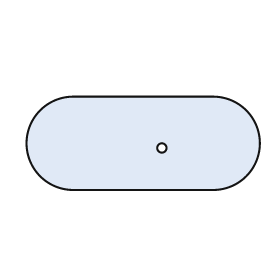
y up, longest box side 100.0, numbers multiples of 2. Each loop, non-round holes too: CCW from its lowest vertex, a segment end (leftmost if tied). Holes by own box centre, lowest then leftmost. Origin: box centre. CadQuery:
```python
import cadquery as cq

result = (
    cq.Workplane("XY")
    .moveTo(-30.0, -20.0)
    .lineTo(30.0, -20.0)
    .threePointArc((50.0, 0.0), (30.0, 20.0))
    .lineTo(-30.0, 20.0)
    .threePointArc((-50.0, 0.0), (-30.0, -20.0))
    .close()
    .moveTo(8.0, -2.0)
    .circle(2.0)
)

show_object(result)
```